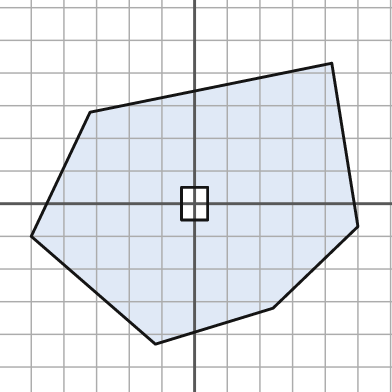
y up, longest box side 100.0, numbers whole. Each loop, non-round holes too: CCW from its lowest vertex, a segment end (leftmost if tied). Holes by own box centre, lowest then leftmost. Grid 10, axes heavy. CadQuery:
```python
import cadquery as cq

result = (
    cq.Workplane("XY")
    .moveTo(-12.0, -43.0)
    .lineTo(24.0, -32.0)
    .lineTo(50.0, -7.0)
    .lineTo(42.0, 43.0)
    .lineTo(-32.0, 28.0)
    .lineTo(-50.0, -10.0)
    .close()
    .moveTo(-4.0, -5.0)
    .lineTo(4.0, -5.0)
    .lineTo(4.0, 5.0)
    .lineTo(-4.0, 5.0)
    .close()
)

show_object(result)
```